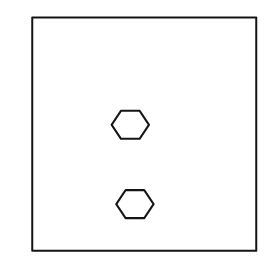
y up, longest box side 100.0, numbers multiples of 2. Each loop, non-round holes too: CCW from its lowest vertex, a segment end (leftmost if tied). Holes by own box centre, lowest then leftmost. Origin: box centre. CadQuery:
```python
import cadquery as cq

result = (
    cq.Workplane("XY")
    .moveTo(-48.0, -50.0)
    .lineTo(48.0, -50.0)
    .lineTo(48.0, 50.0)
    .lineTo(-48.0, 50.0)
    .close()
    .moveTo(-8.0, -36.0)
    .lineTo(0.0, -36.0)
    .lineTo(4.0, -30.0)
    .lineTo(0.0, -24.0)
    .lineTo(-8.0, -24.0)
    .lineTo(-12.0, -30.0)
    .close()
    .moveTo(-10.0, -2.0)
    .lineTo(-2.0, -2.0)
    .lineTo(2.0, 4.0)
    .lineTo(-2.0, 10.0)
    .lineTo(-10.0, 10.0)
    .lineTo(-14.0, 4.0)
    .close()
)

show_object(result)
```